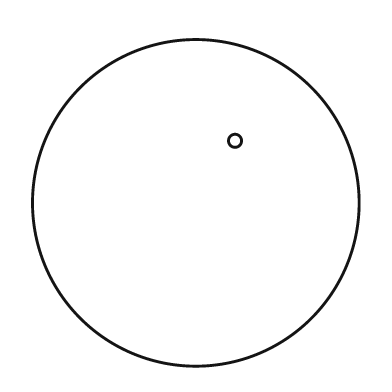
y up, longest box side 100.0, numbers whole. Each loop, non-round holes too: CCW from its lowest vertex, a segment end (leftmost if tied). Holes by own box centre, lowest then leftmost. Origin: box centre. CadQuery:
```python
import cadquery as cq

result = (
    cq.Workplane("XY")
    .moveTo(0.0, 0.0)
    .circle(50.0)
    .moveTo(12.0, 19.0)
    .circle(2.0)
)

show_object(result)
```